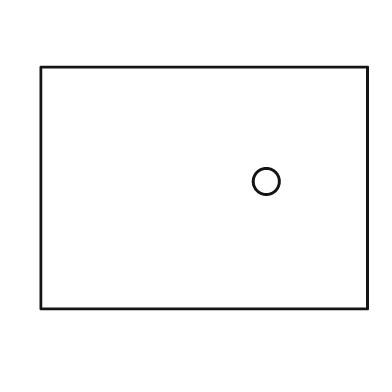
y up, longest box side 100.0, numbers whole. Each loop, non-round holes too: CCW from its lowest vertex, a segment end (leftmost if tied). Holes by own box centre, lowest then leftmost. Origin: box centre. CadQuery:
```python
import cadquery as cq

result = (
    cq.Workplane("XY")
    .moveTo(-50.0, -37.0)
    .lineTo(50.0, -37.0)
    .lineTo(50.0, 37.0)
    .lineTo(-50.0, 37.0)
    .close()
    .moveTo(19.0, 2.0)
    .circle(4.0)
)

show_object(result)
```